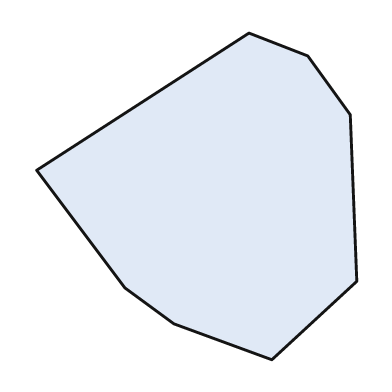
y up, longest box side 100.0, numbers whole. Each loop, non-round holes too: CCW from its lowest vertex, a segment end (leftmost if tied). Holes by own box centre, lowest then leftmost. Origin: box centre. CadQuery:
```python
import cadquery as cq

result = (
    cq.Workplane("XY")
    .moveTo(23.0, -50.0)
    .lineTo(49.0, -26.0)
    .lineTo(47.0, 25.0)
    .lineTo(34.0, 43.0)
    .lineTo(16.0, 50.0)
    .lineTo(-49.0, 8.0)
    .lineTo(-22.0, -28.0)
    .lineTo(-7.0, -39.0)
    .close()
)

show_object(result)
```